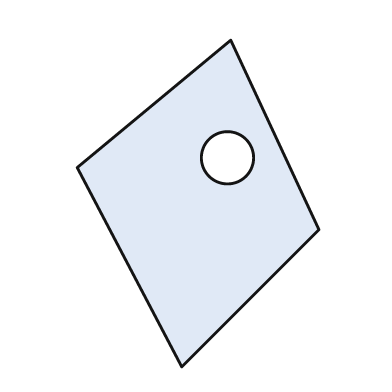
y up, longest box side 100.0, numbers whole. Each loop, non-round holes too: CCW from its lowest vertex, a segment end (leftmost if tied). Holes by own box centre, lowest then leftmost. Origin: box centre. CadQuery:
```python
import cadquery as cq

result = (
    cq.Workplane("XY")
    .moveTo(-5.0, -50.0)
    .lineTo(37.0, -8.0)
    .lineTo(10.0, 50.0)
    .lineTo(-37.0, 11.0)
    .close()
    .moveTo(9.0, 14.0)
    .circle(8.0)
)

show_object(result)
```